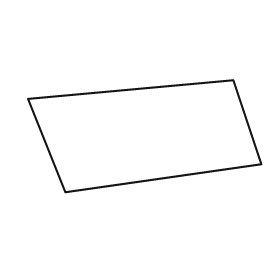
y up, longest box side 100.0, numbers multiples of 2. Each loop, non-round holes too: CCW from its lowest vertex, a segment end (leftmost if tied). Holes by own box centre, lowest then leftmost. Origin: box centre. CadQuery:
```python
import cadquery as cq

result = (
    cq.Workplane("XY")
    .moveTo(-34.0, -24.0)
    .lineTo(50.0, -12.0)
    .lineTo(38.0, 24.0)
    .lineTo(-50.0, 16.0)
    .close()
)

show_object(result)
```